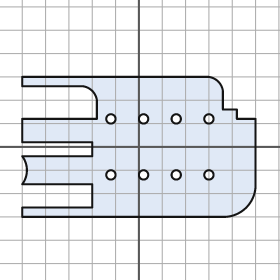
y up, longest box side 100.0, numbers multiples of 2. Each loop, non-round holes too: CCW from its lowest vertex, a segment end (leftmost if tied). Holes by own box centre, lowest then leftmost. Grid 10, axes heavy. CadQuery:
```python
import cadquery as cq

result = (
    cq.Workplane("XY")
    .moveTo(-50.0, -30.0)
    .lineTo(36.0, -30.0)
    .threePointArc((46.0, -26.0), (50.0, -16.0))
    .lineTo(50.0, 12.0)
    .lineTo(42.0, 12.0)
    .lineTo(42.0, 16.0)
    .lineTo(36.0, 16.0)
    .lineTo(36.0, 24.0)
    .threePointArc((34.0, 28.0), (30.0, 30.0))
    .lineTo(-50.0, 30.0)
    .lineTo(-50.0, 26.0)
    .lineTo(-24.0, 26.0)
    .threePointArc((-20.0, 24.0), (-18.0, 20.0))
    .lineTo(-18.0, 12.0)
    .lineTo(-50.0, 12.0)
    .lineTo(-50.0, 2.0)
    .lineTo(-20.0, 2.0)
    .lineTo(-20.0, -4.0)
    .lineTo(-50.0, -4.0)
    .threePointArc((-48.0, -10.0), (-50.0, -16.0))
    .lineTo(-20.0, -16.0)
    .lineTo(-20.0, -26.0)
    .lineTo(-50.0, -26.0)
    .close()
    .moveTo(-12.0, -12.0)
    .circle(2.0)
    .moveTo(2.0, -12.0)
    .circle(2.0)
    .moveTo(16.0, -12.0)
    .circle(2.0)
    .moveTo(30.0, -12.0)
    .circle(2.0)
    .moveTo(-12.0, 12.0)
    .circle(2.0)
    .moveTo(2.0, 12.0)
    .circle(2.0)
    .moveTo(16.0, 12.0)
    .circle(2.0)
    .moveTo(30.0, 12.0)
    .circle(2.0)
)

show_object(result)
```